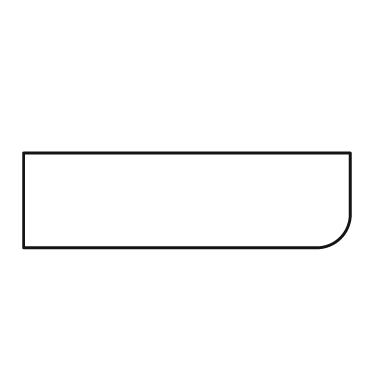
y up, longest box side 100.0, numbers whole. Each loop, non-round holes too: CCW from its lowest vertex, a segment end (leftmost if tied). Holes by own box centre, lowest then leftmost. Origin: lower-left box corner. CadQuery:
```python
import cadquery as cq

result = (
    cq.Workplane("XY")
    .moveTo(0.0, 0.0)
    .lineTo(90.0, 0.0)
    .threePointArc((97.0, 3.0), (100.0, 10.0))
    .lineTo(100.0, 29.0)
    .lineTo(0.0, 29.0)
    .close()
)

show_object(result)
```